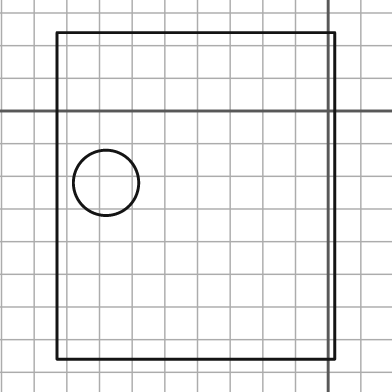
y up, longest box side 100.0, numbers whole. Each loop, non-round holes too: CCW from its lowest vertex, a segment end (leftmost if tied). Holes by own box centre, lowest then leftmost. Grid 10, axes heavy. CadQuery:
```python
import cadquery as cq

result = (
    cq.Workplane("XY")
    .moveTo(-83.0, -76.0)
    .lineTo(2.0, -76.0)
    .lineTo(2.0, 24.0)
    .lineTo(-83.0, 24.0)
    .close()
    .moveTo(-68.0, -22.0)
    .circle(10.0)
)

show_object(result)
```